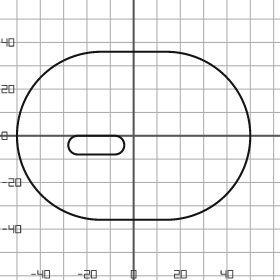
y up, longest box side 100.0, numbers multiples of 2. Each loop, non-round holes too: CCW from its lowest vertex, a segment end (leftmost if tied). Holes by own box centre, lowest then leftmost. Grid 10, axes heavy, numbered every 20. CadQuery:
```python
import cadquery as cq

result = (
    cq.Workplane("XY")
    .moveTo(-14.0, -36.0)
    .lineTo(14.0, -36.0)
    .threePointArc((50.0, 0.0), (14.0, 36.0))
    .lineTo(-14.0, 36.0)
    .threePointArc((-50.0, 0.0), (-14.0, -36.0))
    .close()
    .moveTo(-24.0, -8.0)
    .lineTo(-8.0, -8.0)
    .threePointArc((-4.0, -4.0), (-8.0, 0.0))
    .lineTo(-24.0, 0.0)
    .threePointArc((-28.0, -4.0), (-24.0, -8.0))
    .close()
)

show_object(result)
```